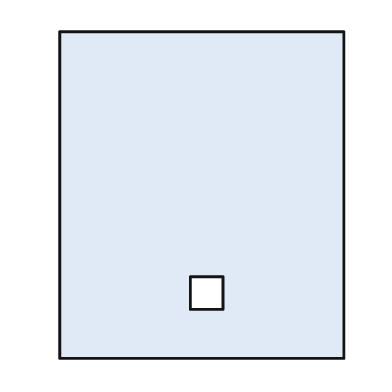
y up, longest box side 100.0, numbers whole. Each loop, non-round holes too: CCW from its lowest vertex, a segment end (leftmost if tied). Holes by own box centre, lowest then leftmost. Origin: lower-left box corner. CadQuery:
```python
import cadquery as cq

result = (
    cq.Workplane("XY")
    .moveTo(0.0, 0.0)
    .lineTo(87.0, 0.0)
    .lineTo(87.0, 100.0)
    .lineTo(0.0, 100.0)
    .close()
    .moveTo(40.0, 15.0)
    .lineTo(50.0, 15.0)
    .lineTo(50.0, 25.0)
    .lineTo(40.0, 25.0)
    .close()
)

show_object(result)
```